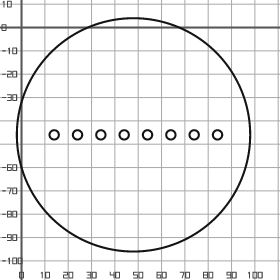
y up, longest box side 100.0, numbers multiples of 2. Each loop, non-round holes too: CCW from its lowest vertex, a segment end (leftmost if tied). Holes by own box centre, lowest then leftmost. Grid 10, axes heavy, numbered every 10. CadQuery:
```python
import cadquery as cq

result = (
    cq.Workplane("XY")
    .moveTo(48.0, -46.0)
    .circle(50.0)
    .moveTo(14.0, -46.0)
    .circle(2.0)
    .moveTo(24.0, -46.0)
    .circle(2.0)
    .moveTo(34.0, -46.0)
    .circle(2.0)
    .moveTo(44.0, -46.0)
    .circle(2.0)
    .moveTo(54.0, -46.0)
    .circle(2.0)
    .moveTo(64.0, -46.0)
    .circle(2.0)
    .moveTo(74.0, -46.0)
    .circle(2.0)
    .moveTo(84.0, -46.0)
    .circle(2.0)
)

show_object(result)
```